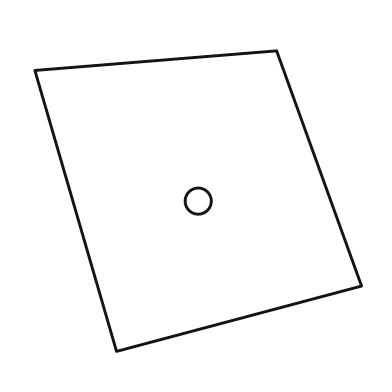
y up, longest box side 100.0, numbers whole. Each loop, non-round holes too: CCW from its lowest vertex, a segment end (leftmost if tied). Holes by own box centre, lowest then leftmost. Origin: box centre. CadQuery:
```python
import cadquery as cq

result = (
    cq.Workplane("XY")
    .moveTo(-25.0, -46.0)
    .lineTo(50.0, -26.0)
    .lineTo(24.0, 46.0)
    .lineTo(-50.0, 40.0)
    .close()
    .moveTo(0.0, 0.0)
    .circle(4.0)
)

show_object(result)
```